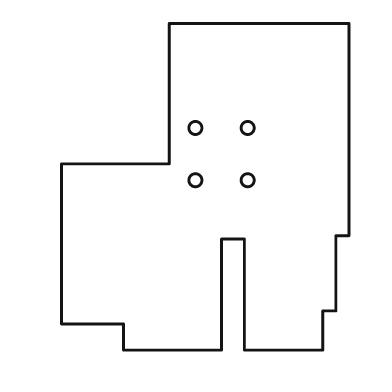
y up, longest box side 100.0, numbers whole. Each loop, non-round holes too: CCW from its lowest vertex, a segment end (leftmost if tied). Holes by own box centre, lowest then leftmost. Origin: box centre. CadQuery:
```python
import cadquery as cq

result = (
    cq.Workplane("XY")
    .moveTo(-25.0, -50.0)
    .lineTo(5.0, -50.0)
    .lineTo(5.0, -16.0)
    .lineTo(12.0, -16.0)
    .lineTo(12.0, -50.0)
    .lineTo(36.0, -50.0)
    .lineTo(36.0, -38.0)
    .lineTo(40.0, -38.0)
    .lineTo(40.0, -15.0)
    .lineTo(44.0, -15.0)
    .lineTo(44.0, 50.0)
    .lineTo(-11.0, 50.0)
    .lineTo(-11.0, 7.0)
    .lineTo(-44.0, 7.0)
    .lineTo(-44.0, -42.0)
    .lineTo(-25.0, -42.0)
    .close()
    .moveTo(-3.0, 2.0)
    .circle(2.0)
    .moveTo(13.0, 2.0)
    .circle(2.0)
    .moveTo(-3.0, 18.0)
    .circle(2.0)
    .moveTo(13.0, 18.0)
    .circle(2.0)
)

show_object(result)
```